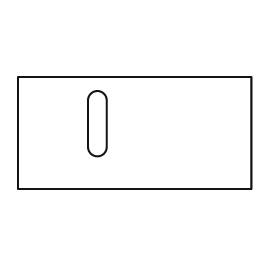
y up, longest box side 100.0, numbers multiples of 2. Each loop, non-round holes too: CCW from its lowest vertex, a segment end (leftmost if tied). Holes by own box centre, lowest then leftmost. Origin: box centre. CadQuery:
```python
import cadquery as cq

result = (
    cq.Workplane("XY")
    .moveTo(-50.0, -24.0)
    .lineTo(50.0, -24.0)
    .lineTo(50.0, 24.0)
    .lineTo(-50.0, 24.0)
    .close()
    .moveTo(-20.0, -6.0)
    .threePointArc((-16.0, -10.0), (-12.0, -6.0))
    .lineTo(-12.0, 14.0)
    .threePointArc((-16.0, 18.0), (-20.0, 14.0))
    .close()
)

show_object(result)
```